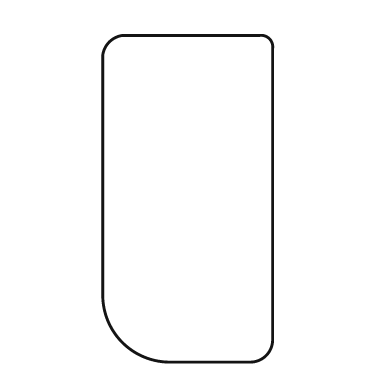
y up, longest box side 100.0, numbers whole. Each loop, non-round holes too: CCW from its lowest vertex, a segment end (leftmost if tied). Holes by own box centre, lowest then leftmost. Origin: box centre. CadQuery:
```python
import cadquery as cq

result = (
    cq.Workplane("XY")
    .moveTo(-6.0, -50.0)
    .lineTo(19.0, -50.0)
    .threePointArc((24.0, -48.0), (26.0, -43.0))
    .lineTo(26.0, 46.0)
    .threePointArc((25.0, 49.0), (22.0, 50.0))
    .lineTo(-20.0, 50.0)
    .threePointArc((-24.0, 48.0), (-26.0, 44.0))
    .lineTo(-26.0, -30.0)
    .threePointArc((-20.0, -44.0), (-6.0, -50.0))
    .close()
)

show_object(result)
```